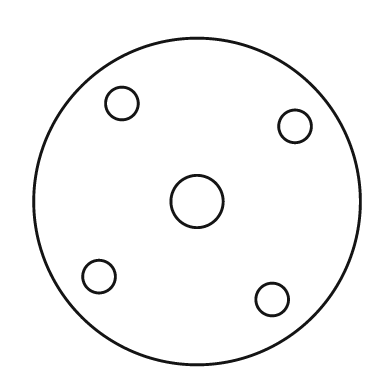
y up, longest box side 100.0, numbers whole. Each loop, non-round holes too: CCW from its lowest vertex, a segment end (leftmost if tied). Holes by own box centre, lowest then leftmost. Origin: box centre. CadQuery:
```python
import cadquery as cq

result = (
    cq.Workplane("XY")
    .moveTo(0.0, 0.0)
    .circle(50.0)
    .moveTo(23.0, -30.0)
    .circle(5.0)
    .moveTo(-30.0, -23.0)
    .circle(5.0)
    .moveTo(0.0, 0.0)
    .circle(8.0)
    .moveTo(30.0, 23.0)
    .circle(5.0)
    .moveTo(-23.0, 30.0)
    .circle(5.0)
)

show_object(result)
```